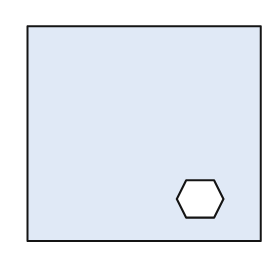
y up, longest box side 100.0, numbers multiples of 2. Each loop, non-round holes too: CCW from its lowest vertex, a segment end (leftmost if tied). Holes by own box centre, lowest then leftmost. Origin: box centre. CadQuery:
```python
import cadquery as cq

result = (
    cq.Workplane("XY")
    .moveTo(-50.0, -46.0)
    .lineTo(50.0, -46.0)
    .lineTo(50.0, 46.0)
    .lineTo(-50.0, 46.0)
    .close()
    .moveTo(18.0, -36.0)
    .lineTo(30.0, -36.0)
    .lineTo(34.0, -28.0)
    .lineTo(30.0, -20.0)
    .lineTo(18.0, -20.0)
    .lineTo(14.0, -28.0)
    .close()
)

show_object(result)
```